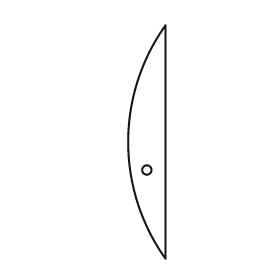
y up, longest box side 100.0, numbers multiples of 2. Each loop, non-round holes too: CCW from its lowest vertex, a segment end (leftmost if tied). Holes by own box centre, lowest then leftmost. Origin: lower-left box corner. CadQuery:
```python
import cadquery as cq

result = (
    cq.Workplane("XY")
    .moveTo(16.0, 0.0)
    .lineTo(16.0, 100.0)
    .threePointArc((0.0, 50.0), (16.0, 0.0))
    .close()
    .moveTo(8.0, 38.0)
    .circle(2.0)
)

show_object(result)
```